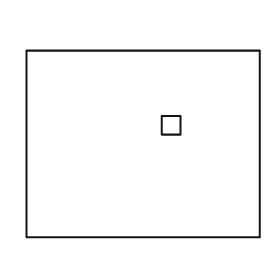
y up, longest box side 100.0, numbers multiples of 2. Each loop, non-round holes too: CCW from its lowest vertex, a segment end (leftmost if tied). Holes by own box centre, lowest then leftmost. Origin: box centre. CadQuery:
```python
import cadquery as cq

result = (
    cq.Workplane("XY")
    .moveTo(-50.0, -40.0)
    .lineTo(50.0, -40.0)
    .lineTo(50.0, 40.0)
    .lineTo(-50.0, 40.0)
    .close()
    .moveTo(8.0, 4.0)
    .lineTo(16.0, 4.0)
    .lineTo(16.0, 12.0)
    .lineTo(8.0, 12.0)
    .close()
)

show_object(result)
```